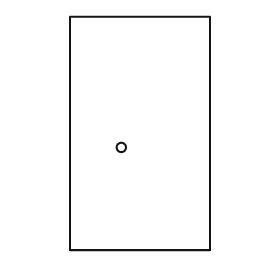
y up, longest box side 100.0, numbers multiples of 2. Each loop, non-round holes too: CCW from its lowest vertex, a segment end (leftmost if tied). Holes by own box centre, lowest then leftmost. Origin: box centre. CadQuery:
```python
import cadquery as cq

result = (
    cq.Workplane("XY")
    .moveTo(-30.0, -50.0)
    .lineTo(30.0, -50.0)
    .lineTo(30.0, 50.0)
    .lineTo(-30.0, 50.0)
    .close()
    .moveTo(-8.0, -6.0)
    .circle(2.0)
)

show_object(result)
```